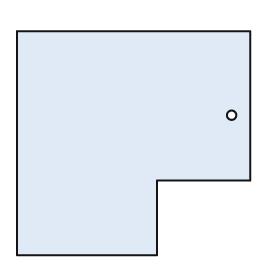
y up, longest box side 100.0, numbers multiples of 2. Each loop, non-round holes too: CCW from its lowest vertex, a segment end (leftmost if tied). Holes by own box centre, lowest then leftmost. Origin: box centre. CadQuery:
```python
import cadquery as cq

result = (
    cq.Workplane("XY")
    .moveTo(-50.0, -48.0)
    .lineTo(10.0, -48.0)
    .lineTo(10.0, -16.0)
    .lineTo(50.0, -16.0)
    .lineTo(50.0, 48.0)
    .lineTo(-50.0, 48.0)
    .close()
    .moveTo(42.0, 12.0)
    .circle(2.0)
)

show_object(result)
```